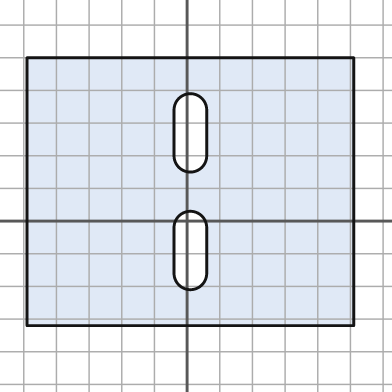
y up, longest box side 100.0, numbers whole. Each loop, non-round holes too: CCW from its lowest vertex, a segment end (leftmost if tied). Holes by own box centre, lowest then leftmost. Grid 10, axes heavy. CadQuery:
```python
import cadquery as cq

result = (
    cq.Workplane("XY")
    .moveTo(-49.0, -32.0)
    .lineTo(51.0, -32.0)
    .lineTo(51.0, 50.0)
    .lineTo(-49.0, 50.0)
    .close()
    .moveTo(-4.0, -16.0)
    .threePointArc((1.0, -21.0), (6.0, -16.0))
    .lineTo(6.0, -2.0)
    .threePointArc((1.0, 3.0), (-4.0, -2.0))
    .close()
    .moveTo(-4.0, 20.0)
    .threePointArc((1.0, 15.0), (6.0, 20.0))
    .lineTo(6.0, 34.0)
    .threePointArc((1.0, 39.0), (-4.0, 34.0))
    .close()
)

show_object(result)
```